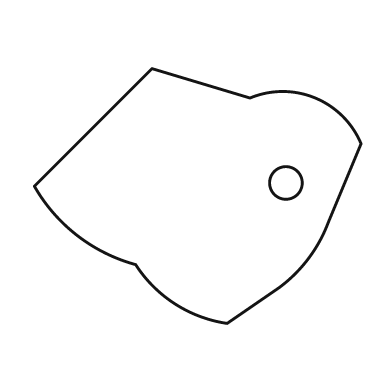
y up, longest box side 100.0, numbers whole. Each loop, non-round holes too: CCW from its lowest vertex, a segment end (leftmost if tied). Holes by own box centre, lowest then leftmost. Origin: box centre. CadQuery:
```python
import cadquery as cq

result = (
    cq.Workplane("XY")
    .moveTo(9.0, -39.0)
    .lineTo(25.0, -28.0)
    .threePointArc((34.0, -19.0), (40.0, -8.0))
    .lineTo(50.0, 16.0)
    .threePointArc((36.0, 30.0), (16.0, 30.0))
    .lineTo(-14.0, 39.0)
    .lineTo(-50.0, 3.0)
    .threePointArc((-37.0, -12.0), (-19.0, -21.0))
    .threePointArc((-7.0, -33.0), (9.0, -39.0))
    .close()
    .moveTo(27.0, 4.0)
    .circle(5.0)
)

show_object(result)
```